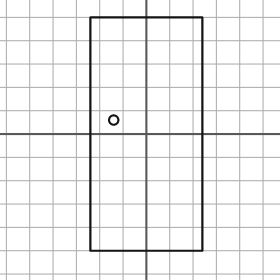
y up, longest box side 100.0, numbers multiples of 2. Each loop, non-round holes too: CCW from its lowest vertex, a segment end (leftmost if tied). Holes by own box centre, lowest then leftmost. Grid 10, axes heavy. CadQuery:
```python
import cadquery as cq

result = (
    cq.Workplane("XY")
    .moveTo(-24.0, -50.0)
    .lineTo(24.0, -50.0)
    .lineTo(24.0, 50.0)
    .lineTo(-24.0, 50.0)
    .close()
    .moveTo(-14.0, 6.0)
    .circle(2.0)
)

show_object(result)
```